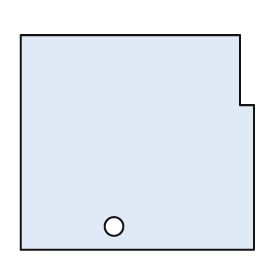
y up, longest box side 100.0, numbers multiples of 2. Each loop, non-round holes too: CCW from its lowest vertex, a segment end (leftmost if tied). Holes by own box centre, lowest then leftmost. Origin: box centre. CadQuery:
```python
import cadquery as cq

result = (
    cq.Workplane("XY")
    .moveTo(-50.0, -46.0)
    .lineTo(50.0, -46.0)
    .lineTo(50.0, 16.0)
    .lineTo(44.0, 16.0)
    .lineTo(44.0, 46.0)
    .lineTo(-50.0, 46.0)
    .close()
    .moveTo(-10.0, -36.0)
    .circle(4.0)
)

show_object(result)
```